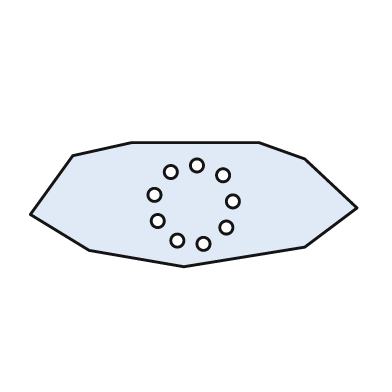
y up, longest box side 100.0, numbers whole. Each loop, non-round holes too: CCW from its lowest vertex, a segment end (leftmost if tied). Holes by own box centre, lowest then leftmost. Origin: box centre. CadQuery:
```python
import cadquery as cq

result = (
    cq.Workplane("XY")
    .moveTo(-3.0, -19.0)
    .lineTo(34.0, -13.0)
    .lineTo(50.0, -1.0)
    .lineTo(34.0, 14.0)
    .lineTo(20.0, 19.0)
    .lineTo(-19.0, 19.0)
    .lineTo(-37.0, 15.0)
    .lineTo(-50.0, -3.0)
    .lineTo(-32.0, -14.0)
    .close()
    .moveTo(3.0, -12.0)
    .circle(2.0)
    .moveTo(-5.0, -11.0)
    .circle(2.0)
    .moveTo(10.0, -7.0)
    .circle(2.0)
    .moveTo(-11.0, -5.0)
    .circle(2.0)
    .moveTo(12.0, 1.0)
    .circle(2.0)
    .moveTo(-12.0, 3.0)
    .circle(2.0)
    .moveTo(9.0, 9.0)
    .circle(2.0)
    .moveTo(-7.0, 10.0)
    .circle(2.0)
    .moveTo(1.0, 12.0)
    .circle(2.0)
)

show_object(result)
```